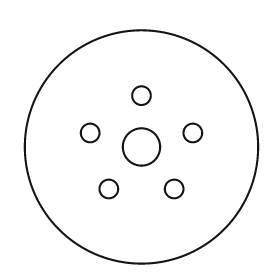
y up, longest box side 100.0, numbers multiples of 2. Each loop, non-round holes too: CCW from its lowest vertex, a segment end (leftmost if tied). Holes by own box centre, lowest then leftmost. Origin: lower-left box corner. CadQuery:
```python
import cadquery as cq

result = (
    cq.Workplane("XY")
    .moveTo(50.0, 50.0)
    .circle(50.0)
    .moveTo(36.0, 32.0)
    .circle(4.0)
    .moveTo(64.0, 32.0)
    .circle(4.0)
    .moveTo(50.0, 50.0)
    .circle(8.0)
    .moveTo(28.0, 56.0)
    .circle(4.0)
    .moveTo(72.0, 56.0)
    .circle(4.0)
    .moveTo(50.0, 72.0)
    .circle(4.0)
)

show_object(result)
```